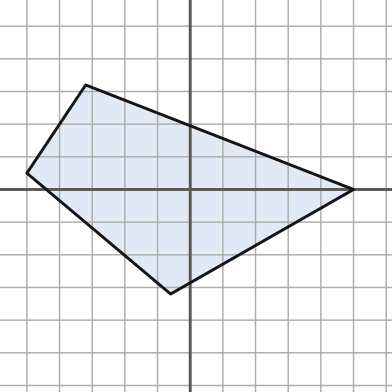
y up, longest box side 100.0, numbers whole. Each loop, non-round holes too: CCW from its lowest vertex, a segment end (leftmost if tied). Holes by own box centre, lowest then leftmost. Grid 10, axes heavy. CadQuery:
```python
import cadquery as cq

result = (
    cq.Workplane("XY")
    .moveTo(-6.0, -32.0)
    .lineTo(50.0, 0.0)
    .lineTo(-32.0, 32.0)
    .lineTo(-50.0, 5.0)
    .close()
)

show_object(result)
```